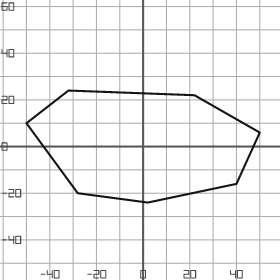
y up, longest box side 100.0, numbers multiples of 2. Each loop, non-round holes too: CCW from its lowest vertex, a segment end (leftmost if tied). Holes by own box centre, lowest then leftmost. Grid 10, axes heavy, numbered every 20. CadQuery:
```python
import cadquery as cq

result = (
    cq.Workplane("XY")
    .moveTo(2.0, -24.0)
    .lineTo(40.0, -16.0)
    .lineTo(50.0, 6.0)
    .lineTo(22.0, 22.0)
    .lineTo(-32.0, 24.0)
    .lineTo(-50.0, 10.0)
    .lineTo(-28.0, -20.0)
    .close()
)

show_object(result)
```